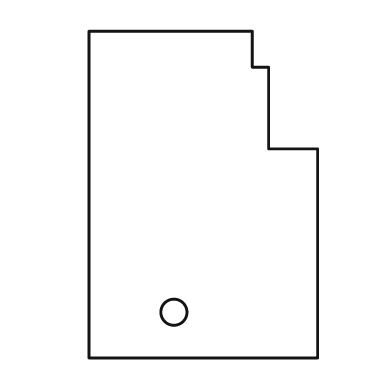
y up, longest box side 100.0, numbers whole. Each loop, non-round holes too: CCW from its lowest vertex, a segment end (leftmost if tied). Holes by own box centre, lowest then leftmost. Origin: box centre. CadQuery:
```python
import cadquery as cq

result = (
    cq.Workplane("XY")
    .moveTo(-35.0, -50.0)
    .lineTo(35.0, -50.0)
    .lineTo(35.0, 14.0)
    .lineTo(20.0, 14.0)
    .lineTo(20.0, 39.0)
    .lineTo(15.0, 39.0)
    .lineTo(15.0, 50.0)
    .lineTo(-35.0, 50.0)
    .close()
    .moveTo(-9.0, -36.0)
    .circle(4.0)
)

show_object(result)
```